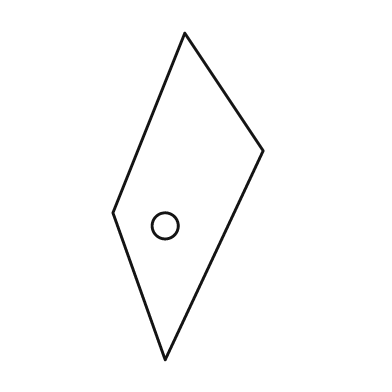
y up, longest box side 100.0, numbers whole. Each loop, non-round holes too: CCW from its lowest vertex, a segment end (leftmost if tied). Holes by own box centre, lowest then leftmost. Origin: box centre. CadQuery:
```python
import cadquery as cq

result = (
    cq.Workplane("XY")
    .moveTo(-7.0, -50.0)
    .lineTo(23.0, 14.0)
    .lineTo(-1.0, 50.0)
    .lineTo(-23.0, -5.0)
    .close()
    .moveTo(-7.0, -9.0)
    .circle(4.0)
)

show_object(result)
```